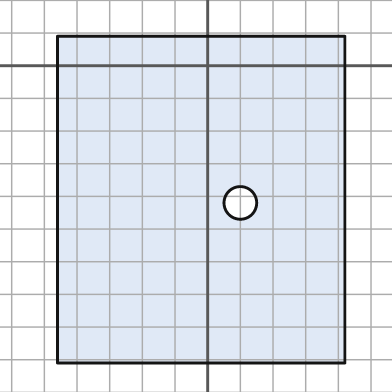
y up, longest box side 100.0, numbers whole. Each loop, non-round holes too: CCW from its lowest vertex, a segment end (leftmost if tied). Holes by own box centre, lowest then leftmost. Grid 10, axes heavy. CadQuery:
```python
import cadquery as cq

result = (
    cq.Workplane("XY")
    .moveTo(-46.0, -91.0)
    .lineTo(42.0, -91.0)
    .lineTo(42.0, 9.0)
    .lineTo(-46.0, 9.0)
    .close()
    .moveTo(10.0, -42.0)
    .circle(5.0)
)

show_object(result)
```